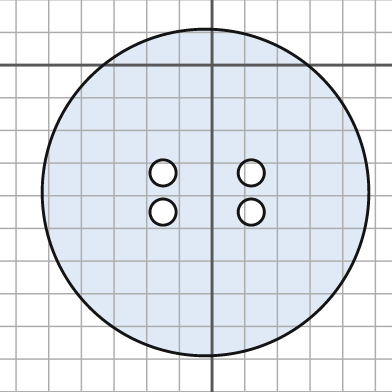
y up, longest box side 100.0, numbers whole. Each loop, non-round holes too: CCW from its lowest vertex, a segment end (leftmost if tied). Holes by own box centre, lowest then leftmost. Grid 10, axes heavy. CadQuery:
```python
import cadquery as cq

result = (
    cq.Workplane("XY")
    .moveTo(-2.0, -39.0)
    .circle(50.0)
    .moveTo(-15.0, -45.0)
    .circle(4.0)
    .moveTo(12.0, -45.0)
    .circle(4.0)
    .moveTo(-15.0, -33.0)
    .circle(4.0)
    .moveTo(12.0, -33.0)
    .circle(4.0)
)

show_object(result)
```